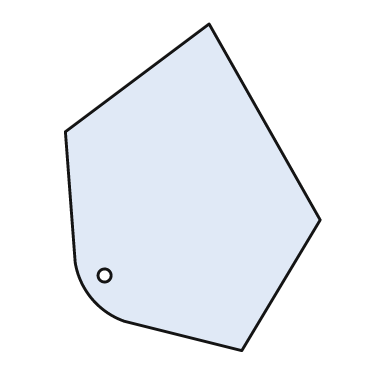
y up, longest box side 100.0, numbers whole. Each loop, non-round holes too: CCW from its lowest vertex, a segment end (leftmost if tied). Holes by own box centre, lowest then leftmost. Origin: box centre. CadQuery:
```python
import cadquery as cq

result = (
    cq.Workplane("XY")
    .moveTo(15.0, -50.0)
    .lineTo(39.0, -10.0)
    .lineTo(5.0, 50.0)
    .lineTo(-39.0, 17.0)
    .lineTo(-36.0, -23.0)
    .threePointArc((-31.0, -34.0), (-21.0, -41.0))
    .close()
    .moveTo(-27.0, -27.0)
    .circle(2.0)
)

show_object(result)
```